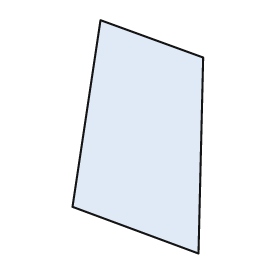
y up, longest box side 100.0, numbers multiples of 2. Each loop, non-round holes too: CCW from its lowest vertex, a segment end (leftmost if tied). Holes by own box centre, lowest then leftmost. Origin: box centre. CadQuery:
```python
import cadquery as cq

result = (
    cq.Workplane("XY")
    .moveTo(26.0, -50.0)
    .lineTo(28.0, 34.0)
    .lineTo(-16.0, 50.0)
    .lineTo(-28.0, -30.0)
    .close()
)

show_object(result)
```